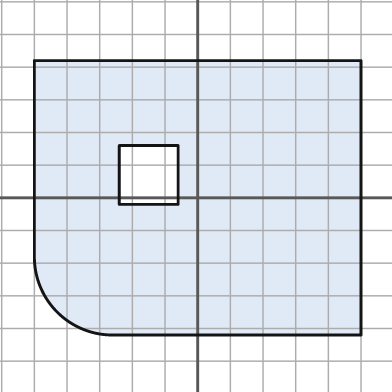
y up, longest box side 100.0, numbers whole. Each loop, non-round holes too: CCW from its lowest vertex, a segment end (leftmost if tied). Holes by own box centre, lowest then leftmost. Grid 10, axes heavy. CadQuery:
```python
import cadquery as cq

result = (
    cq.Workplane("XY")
    .moveTo(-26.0, -42.0)
    .lineTo(50.0, -42.0)
    .lineTo(50.0, 42.0)
    .lineTo(-50.0, 42.0)
    .lineTo(-50.0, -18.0)
    .threePointArc((-43.0, -35.0), (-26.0, -42.0))
    .close()
    .moveTo(-24.0, -2.0)
    .lineTo(-6.0, -2.0)
    .lineTo(-6.0, 16.0)
    .lineTo(-24.0, 16.0)
    .close()
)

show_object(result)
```